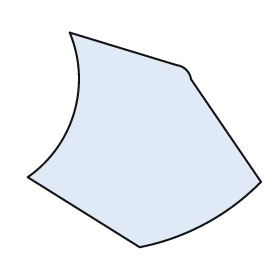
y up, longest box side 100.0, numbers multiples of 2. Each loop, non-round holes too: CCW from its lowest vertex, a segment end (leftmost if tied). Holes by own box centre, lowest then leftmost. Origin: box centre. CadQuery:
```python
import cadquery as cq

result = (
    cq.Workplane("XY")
    .moveTo(-2.0, -46.0)
    .threePointArc((26.0, -36.0), (50.0, -18.0))
    .lineTo(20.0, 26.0)
    .threePointArc((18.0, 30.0), (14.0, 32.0))
    .lineTo(-32.0, 46.0)
    .threePointArc((-30.0, 12.0), (-50.0, -16.0))
    .close()
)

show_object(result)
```